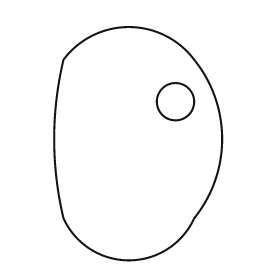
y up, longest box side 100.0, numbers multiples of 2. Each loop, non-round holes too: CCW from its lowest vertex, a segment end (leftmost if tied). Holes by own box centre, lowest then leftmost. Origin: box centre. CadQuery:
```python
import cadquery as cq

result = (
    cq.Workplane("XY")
    .moveTo(-32.0, -32.0)
    .threePointArc((-4.0, -50.0), (24.0, -32.0))
    .threePointArc((36.0, 2.0), (24.0, 36.0))
    .threePointArc((-4.0, 50.0), (-32.0, 36.0))
    .threePointArc((-36.0, 2.0), (-32.0, -32.0))
    .close()
    .moveTo(16.0, 18.0)
    .circle(8.0)
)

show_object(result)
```